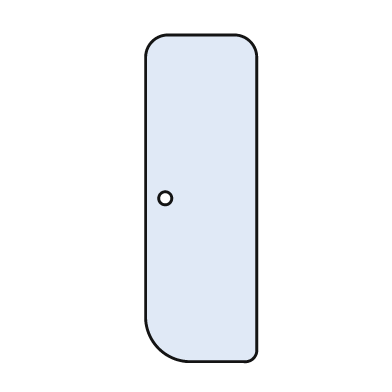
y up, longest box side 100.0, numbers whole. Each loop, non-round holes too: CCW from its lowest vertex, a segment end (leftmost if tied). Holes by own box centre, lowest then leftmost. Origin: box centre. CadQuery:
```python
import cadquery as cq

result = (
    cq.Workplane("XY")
    .moveTo(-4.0, -50.0)
    .lineTo(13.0, -50.0)
    .threePointArc((16.0, -49.0), (17.0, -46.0))
    .lineTo(17.0, 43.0)
    .threePointArc((15.0, 48.0), (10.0, 50.0))
    .lineTo(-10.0, 50.0)
    .threePointArc((-15.0, 48.0), (-17.0, 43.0))
    .lineTo(-17.0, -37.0)
    .threePointArc((-13.0, -46.0), (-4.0, -50.0))
    .close()
    .moveTo(-11.0, 0.0)
    .circle(2.0)
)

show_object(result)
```